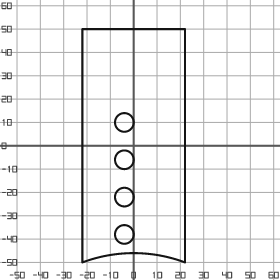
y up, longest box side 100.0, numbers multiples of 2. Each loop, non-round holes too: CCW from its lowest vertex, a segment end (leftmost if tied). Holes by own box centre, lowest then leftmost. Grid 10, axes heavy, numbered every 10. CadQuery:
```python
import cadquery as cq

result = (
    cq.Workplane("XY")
    .moveTo(-22.0, -50.0)
    .threePointArc((0.0, -46.0), (22.0, -50.0))
    .lineTo(22.0, 50.0)
    .lineTo(-22.0, 50.0)
    .close()
    .moveTo(-4.0, -38.0)
    .circle(4.0)
    .moveTo(-4.0, -22.0)
    .circle(4.0)
    .moveTo(-4.0, -6.0)
    .circle(4.0)
    .moveTo(-4.0, 10.0)
    .circle(4.0)
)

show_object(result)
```